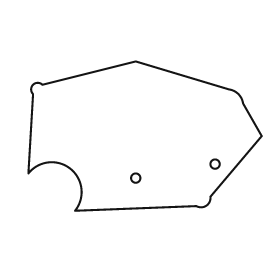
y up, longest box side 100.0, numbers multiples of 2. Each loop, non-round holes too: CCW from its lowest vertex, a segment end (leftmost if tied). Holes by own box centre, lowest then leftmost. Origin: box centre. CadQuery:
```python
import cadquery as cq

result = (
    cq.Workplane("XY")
    .moveTo(-30.0, -32.0)
    .lineTo(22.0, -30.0)
    .threePointArc((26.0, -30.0), (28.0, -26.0))
    .lineTo(50.0, 0.0)
    .lineTo(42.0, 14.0)
    .threePointArc((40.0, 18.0), (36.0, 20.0))
    .lineTo(-4.0, 32.0)
    .lineTo(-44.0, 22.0)
    .threePointArc((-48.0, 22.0), (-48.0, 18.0))
    .lineTo(-50.0, -16.0)
    .threePointArc((-32.0, -14.0), (-30.0, -32.0))
    .close()
    .moveTo(-4.0, -18.0)
    .circle(2.0)
    .moveTo(30.0, -12.0)
    .circle(2.0)
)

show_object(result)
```